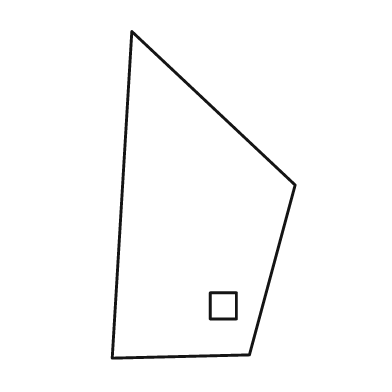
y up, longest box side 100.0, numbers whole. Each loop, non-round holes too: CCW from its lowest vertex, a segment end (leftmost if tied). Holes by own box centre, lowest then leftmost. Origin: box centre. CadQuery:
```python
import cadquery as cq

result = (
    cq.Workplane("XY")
    .moveTo(-28.0, -50.0)
    .lineTo(14.0, -49.0)
    .lineTo(28.0, 3.0)
    .lineTo(-22.0, 50.0)
    .close()
    .moveTo(2.0, -38.0)
    .lineTo(10.0, -38.0)
    .lineTo(10.0, -30.0)
    .lineTo(2.0, -30.0)
    .close()
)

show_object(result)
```